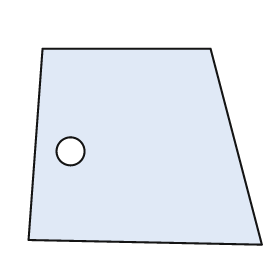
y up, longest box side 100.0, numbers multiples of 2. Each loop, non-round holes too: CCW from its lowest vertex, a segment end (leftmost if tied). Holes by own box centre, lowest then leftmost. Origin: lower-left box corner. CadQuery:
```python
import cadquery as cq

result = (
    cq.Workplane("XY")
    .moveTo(100.0, 0.0)
    .lineTo(78.0, 84.0)
    .lineTo(6.0, 84.0)
    .lineTo(0.0, 2.0)
    .close()
    .moveTo(18.0, 40.0)
    .circle(6.0)
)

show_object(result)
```